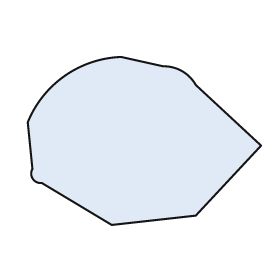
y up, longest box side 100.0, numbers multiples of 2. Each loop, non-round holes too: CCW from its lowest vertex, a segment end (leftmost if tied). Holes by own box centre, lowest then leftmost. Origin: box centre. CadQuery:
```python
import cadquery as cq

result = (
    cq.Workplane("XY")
    .moveTo(-14.0, -36.0)
    .lineTo(22.0, -32.0)
    .lineTo(50.0, -2.0)
    .lineTo(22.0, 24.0)
    .threePointArc((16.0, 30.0), (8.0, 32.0))
    .lineTo(-10.0, 36.0)
    .threePointArc((-34.0, 28.0), (-50.0, 8.0))
    .lineTo(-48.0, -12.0)
    .threePointArc((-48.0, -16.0), (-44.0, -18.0))
    .close()
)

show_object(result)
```